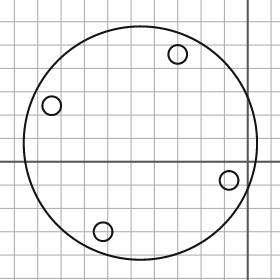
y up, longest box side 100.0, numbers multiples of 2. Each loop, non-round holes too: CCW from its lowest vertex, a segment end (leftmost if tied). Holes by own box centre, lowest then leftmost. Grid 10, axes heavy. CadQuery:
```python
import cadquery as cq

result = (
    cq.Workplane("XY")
    .moveTo(-46.0, 8.0)
    .circle(50.0)
    .moveTo(-62.0, -30.0)
    .circle(4.0)
    .moveTo(-8.0, -8.0)
    .circle(4.0)
    .moveTo(-84.0, 24.0)
    .circle(4.0)
    .moveTo(-30.0, 46.0)
    .circle(4.0)
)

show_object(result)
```